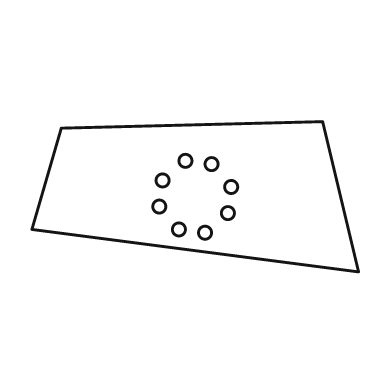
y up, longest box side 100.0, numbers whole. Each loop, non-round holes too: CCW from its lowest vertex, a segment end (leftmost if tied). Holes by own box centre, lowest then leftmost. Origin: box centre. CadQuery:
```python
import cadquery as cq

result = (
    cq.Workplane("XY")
    .moveTo(50.0, -23.0)
    .lineTo(39.0, 23.0)
    .lineTo(-41.0, 21.0)
    .lineTo(-50.0, -10.0)
    .close()
    .moveTo(3.0, -11.0)
    .circle(2.0)
    .moveTo(-5.0, -10.0)
    .circle(2.0)
    .moveTo(10.0, -5.0)
    .circle(2.0)
    .moveTo(-11.0, -3.0)
    .circle(2.0)
    .moveTo(11.0, 3.0)
    .circle(2.0)
    .moveTo(-10.0, 5.0)
    .circle(2.0)
    .moveTo(5.0, 10.0)
    .circle(2.0)
    .moveTo(-3.0, 11.0)
    .circle(2.0)
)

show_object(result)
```